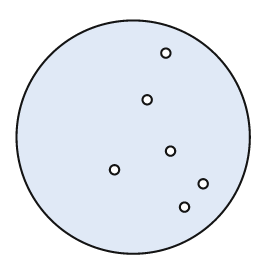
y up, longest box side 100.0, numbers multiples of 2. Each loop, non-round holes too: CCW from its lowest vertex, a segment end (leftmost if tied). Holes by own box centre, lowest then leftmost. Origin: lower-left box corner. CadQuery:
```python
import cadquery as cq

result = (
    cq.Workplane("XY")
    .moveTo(50.0, 50.0)
    .circle(50.0)
    .moveTo(72.0, 20.0)
    .circle(2.0)
    .moveTo(80.0, 30.0)
    .circle(2.0)
    .moveTo(42.0, 36.0)
    .circle(2.0)
    .moveTo(66.0, 44.0)
    .circle(2.0)
    .moveTo(56.0, 66.0)
    .circle(2.0)
    .moveTo(64.0, 86.0)
    .circle(2.0)
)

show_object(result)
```